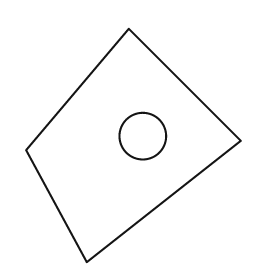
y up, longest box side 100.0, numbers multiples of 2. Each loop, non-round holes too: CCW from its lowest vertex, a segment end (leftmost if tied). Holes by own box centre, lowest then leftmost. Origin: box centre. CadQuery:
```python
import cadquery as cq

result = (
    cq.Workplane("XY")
    .moveTo(-20.0, -50.0)
    .lineTo(46.0, 2.0)
    .lineTo(-2.0, 50.0)
    .lineTo(-46.0, -2.0)
    .close()
    .moveTo(4.0, 4.0)
    .circle(10.0)
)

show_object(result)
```